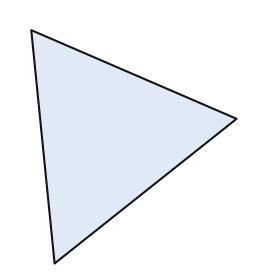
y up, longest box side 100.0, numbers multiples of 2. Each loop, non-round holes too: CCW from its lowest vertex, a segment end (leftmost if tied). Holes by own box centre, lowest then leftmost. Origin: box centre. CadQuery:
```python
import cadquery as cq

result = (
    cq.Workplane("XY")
    .moveTo(-34.0, -50.0)
    .lineTo(44.0, 12.0)
    .lineTo(-44.0, 50.0)
    .close()
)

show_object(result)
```